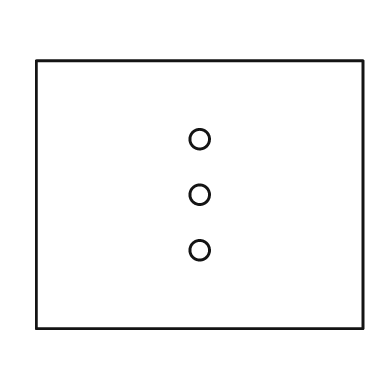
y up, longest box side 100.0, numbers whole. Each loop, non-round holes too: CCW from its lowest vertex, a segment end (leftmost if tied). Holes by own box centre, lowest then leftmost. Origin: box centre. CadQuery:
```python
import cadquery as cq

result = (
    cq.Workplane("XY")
    .moveTo(-50.0, -41.0)
    .lineTo(50.0, -41.0)
    .lineTo(50.0, 41.0)
    .lineTo(-50.0, 41.0)
    .close()
    .moveTo(0.0, -17.0)
    .circle(3.0)
    .moveTo(0.0, 0.0)
    .circle(3.0)
    .moveTo(0.0, 17.0)
    .circle(3.0)
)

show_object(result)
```